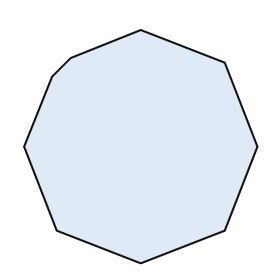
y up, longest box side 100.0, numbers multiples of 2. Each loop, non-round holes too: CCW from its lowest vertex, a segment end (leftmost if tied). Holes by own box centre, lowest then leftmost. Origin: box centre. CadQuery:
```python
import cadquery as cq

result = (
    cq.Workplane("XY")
    .moveTo(0.0, -50.0)
    .lineTo(36.0, -36.0)
    .lineTo(50.0, 0.0)
    .lineTo(36.0, 36.0)
    .lineTo(0.0, 50.0)
    .lineTo(-30.0, 38.0)
    .lineTo(-38.0, 30.0)
    .lineTo(-50.0, 0.0)
    .lineTo(-36.0, -36.0)
    .close()
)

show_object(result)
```